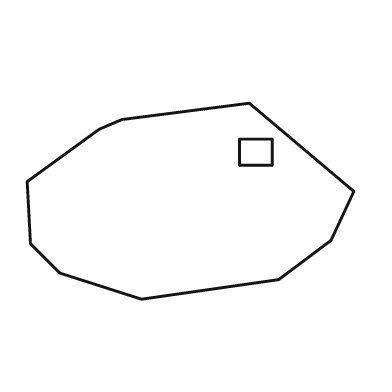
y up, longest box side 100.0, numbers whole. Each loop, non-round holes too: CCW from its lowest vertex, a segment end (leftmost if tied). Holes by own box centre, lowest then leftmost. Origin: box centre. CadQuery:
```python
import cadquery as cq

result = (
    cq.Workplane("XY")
    .moveTo(-15.0, -30.0)
    .lineTo(27.0, -24.0)
    .lineTo(43.0, -12.0)
    .lineTo(50.0, 3.0)
    .lineTo(18.0, 30.0)
    .lineTo(-21.0, 25.0)
    .lineTo(-28.0, 22.0)
    .lineTo(-50.0, 6.0)
    .lineTo(-49.0, -13.0)
    .lineTo(-40.0, -22.0)
    .close()
    .moveTo(15.0, 11.0)
    .lineTo(25.0, 11.0)
    .lineTo(25.0, 19.0)
    .lineTo(15.0, 19.0)
    .close()
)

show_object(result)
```